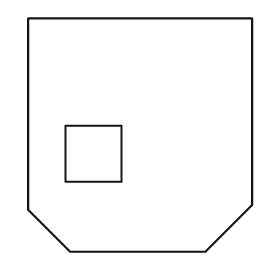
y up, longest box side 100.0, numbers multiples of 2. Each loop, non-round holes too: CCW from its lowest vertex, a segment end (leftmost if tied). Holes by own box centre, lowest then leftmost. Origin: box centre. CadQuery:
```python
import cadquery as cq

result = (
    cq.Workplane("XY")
    .moveTo(-30.0, -50.0)
    .lineTo(28.0, -50.0)
    .lineTo(48.0, -30.0)
    .lineTo(48.0, 50.0)
    .lineTo(-48.0, 50.0)
    .lineTo(-48.0, -32.0)
    .close()
    .moveTo(-32.0, -20.0)
    .lineTo(-8.0, -20.0)
    .lineTo(-8.0, 4.0)
    .lineTo(-32.0, 4.0)
    .close()
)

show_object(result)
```